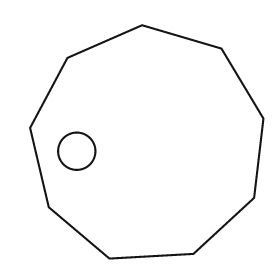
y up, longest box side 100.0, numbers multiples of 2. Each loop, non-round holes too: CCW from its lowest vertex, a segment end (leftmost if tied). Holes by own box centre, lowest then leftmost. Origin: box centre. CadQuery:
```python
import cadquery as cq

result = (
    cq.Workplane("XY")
    .moveTo(-16.0, -50.0)
    .lineTo(20.0, -48.0)
    .lineTo(46.0, -24.0)
    .lineTo(50.0, 10.0)
    .lineTo(32.0, 40.0)
    .lineTo(-2.0, 50.0)
    .lineTo(-34.0, 36.0)
    .lineTo(-50.0, 6.0)
    .lineTo(-42.0, -28.0)
    .close()
    .moveTo(-30.0, -4.0)
    .circle(8.0)
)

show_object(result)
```